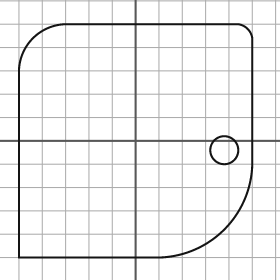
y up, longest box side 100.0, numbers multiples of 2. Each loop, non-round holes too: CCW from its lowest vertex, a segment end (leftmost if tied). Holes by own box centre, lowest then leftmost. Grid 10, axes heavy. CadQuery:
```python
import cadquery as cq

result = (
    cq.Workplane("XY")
    .moveTo(-50.0, -50.0)
    .lineTo(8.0, -50.0)
    .threePointArc((38.0, -38.0), (50.0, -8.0))
    .lineTo(50.0, 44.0)
    .threePointArc((48.0, 48.0), (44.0, 50.0))
    .lineTo(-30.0, 50.0)
    .threePointArc((-44.0, 44.0), (-50.0, 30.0))
    .close()
    .moveTo(38.0, -4.0)
    .circle(6.0)
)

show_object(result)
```